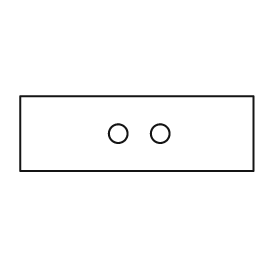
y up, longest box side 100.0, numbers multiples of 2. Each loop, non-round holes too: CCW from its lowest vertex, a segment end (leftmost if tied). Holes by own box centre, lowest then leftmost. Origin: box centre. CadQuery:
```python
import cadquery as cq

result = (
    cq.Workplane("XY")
    .moveTo(-50.0, -16.0)
    .lineTo(50.0, -16.0)
    .lineTo(50.0, 16.0)
    .lineTo(-50.0, 16.0)
    .close()
    .moveTo(-8.0, 0.0)
    .circle(4.0)
    .moveTo(10.0, 0.0)
    .circle(4.0)
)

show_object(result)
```